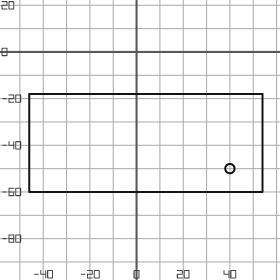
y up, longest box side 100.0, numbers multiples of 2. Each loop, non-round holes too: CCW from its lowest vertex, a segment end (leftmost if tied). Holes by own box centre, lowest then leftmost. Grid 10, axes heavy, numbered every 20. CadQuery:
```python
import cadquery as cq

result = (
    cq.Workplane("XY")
    .moveTo(-46.0, -60.0)
    .lineTo(54.0, -60.0)
    .lineTo(54.0, -18.0)
    .lineTo(-46.0, -18.0)
    .close()
    .moveTo(40.0, -50.0)
    .circle(2.0)
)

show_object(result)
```